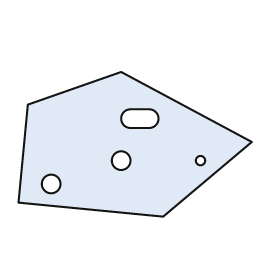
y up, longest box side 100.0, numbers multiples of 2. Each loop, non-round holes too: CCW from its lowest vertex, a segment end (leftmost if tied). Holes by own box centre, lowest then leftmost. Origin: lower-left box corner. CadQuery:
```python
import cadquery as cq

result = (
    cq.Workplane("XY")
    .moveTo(62.0, 0.0)
    .lineTo(100.0, 32.0)
    .lineTo(44.0, 62.0)
    .lineTo(4.0, 48.0)
    .lineTo(0.0, 6.0)
    .close()
    .moveTo(14.0, 14.0)
    .circle(4.0)
    .moveTo(44.0, 24.0)
    .circle(4.0)
    .moveTo(78.0, 24.0)
    .circle(2.0)
    .moveTo(48.0, 38.0)
    .lineTo(56.0, 38.0)
    .threePointArc((60.0, 42.0), (56.0, 46.0))
    .lineTo(48.0, 46.0)
    .threePointArc((44.0, 42.0), (48.0, 38.0))
    .close()
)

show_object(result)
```